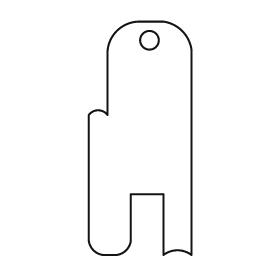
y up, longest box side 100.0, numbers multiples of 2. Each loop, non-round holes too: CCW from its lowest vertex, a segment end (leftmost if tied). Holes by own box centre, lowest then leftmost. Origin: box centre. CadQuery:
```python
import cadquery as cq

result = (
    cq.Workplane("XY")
    .moveTo(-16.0, -50.0)
    .lineTo(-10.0, -50.0)
    .threePointArc((-6.0, -48.0), (-4.0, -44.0))
    .lineTo(-4.0, -24.0)
    .lineTo(10.0, -24.0)
    .lineTo(10.0, -50.0)
    .threePointArc((16.0, -48.0), (22.0, -50.0))
    .lineTo(22.0, 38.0)
    .threePointArc((18.0, 46.0), (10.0, 50.0))
    .lineTo(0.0, 50.0)
    .threePointArc((-10.0, 46.0), (-14.0, 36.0))
    .lineTo(-14.0, 10.0)
    .threePointArc((-18.0, 12.0), (-22.0, 10.0))
    .lineTo(-22.0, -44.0)
    .threePointArc((-20.0, -48.0), (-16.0, -50.0))
    .close()
    .moveTo(4.0, 42.0)
    .circle(4.0)
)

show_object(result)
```